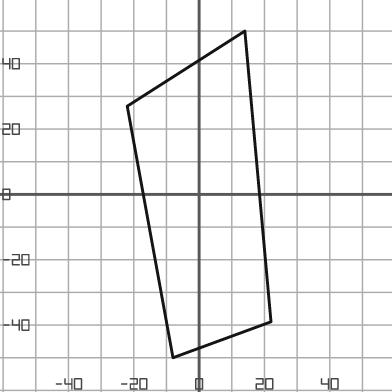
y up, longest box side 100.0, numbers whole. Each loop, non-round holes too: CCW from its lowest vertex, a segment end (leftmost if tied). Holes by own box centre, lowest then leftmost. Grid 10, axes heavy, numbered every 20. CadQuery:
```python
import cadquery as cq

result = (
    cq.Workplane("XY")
    .moveTo(-8.0, -50.0)
    .lineTo(22.0, -39.0)
    .lineTo(14.0, 50.0)
    .lineTo(-22.0, 27.0)
    .close()
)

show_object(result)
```